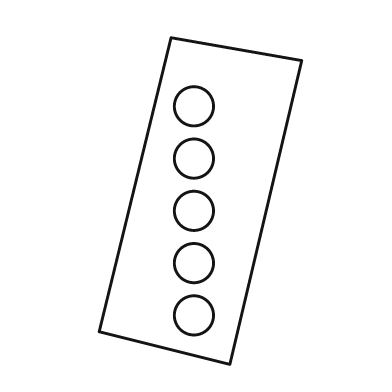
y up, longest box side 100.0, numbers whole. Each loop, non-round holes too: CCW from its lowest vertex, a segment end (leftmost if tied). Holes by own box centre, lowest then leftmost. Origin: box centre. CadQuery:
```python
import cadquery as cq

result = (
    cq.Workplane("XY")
    .moveTo(9.0, -50.0)
    .lineTo(31.0, 43.0)
    .lineTo(-9.0, 50.0)
    .lineTo(-31.0, -40.0)
    .close()
    .moveTo(-2.0, -35.0)
    .circle(6.0)
    .moveTo(-2.0, -19.0)
    .circle(6.0)
    .moveTo(-2.0, -3.0)
    .circle(6.0)
    .moveTo(-2.0, 13.0)
    .circle(6.0)
    .moveTo(-2.0, 29.0)
    .circle(6.0)
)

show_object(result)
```